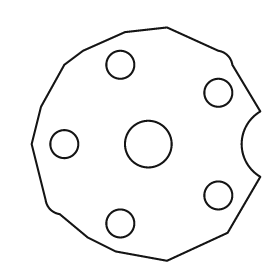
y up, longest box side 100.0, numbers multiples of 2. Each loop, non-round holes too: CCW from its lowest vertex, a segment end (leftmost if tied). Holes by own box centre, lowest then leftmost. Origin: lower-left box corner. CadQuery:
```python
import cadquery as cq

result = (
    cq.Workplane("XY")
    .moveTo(58.0, 0.0)
    .lineTo(84.0, 12.0)
    .lineTo(98.0, 36.0)
    .threePointArc((90.0, 50.0), (98.0, 64.0))
    .lineTo(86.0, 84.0)
    .threePointArc((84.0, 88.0), (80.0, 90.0))
    .lineTo(58.0, 100.0)
    .lineTo(40.0, 98.0)
    .lineTo(22.0, 90.0)
    .lineTo(14.0, 84.0)
    .lineTo(4.0, 66.0)
    .lineTo(0.0, 50.0)
    .lineTo(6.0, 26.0)
    .threePointArc((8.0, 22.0), (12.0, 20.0))
    .lineTo(24.0, 10.0)
    .lineTo(36.0, 4.0)
    .close()
    .moveTo(38.0, 16.0)
    .circle(6.0)
    .moveTo(80.0, 28.0)
    .circle(6.0)
    .moveTo(14.0, 50.0)
    .circle(6.0)
    .moveTo(50.0, 50.0)
    .circle(10.0)
    .moveTo(80.0, 72.0)
    .circle(6.0)
    .moveTo(38.0, 84.0)
    .circle(6.0)
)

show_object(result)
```